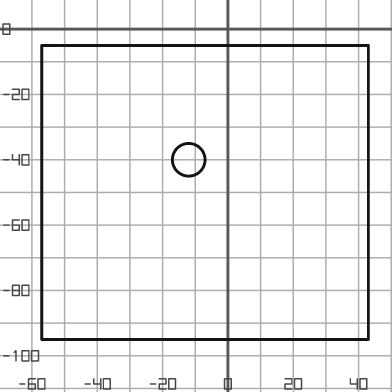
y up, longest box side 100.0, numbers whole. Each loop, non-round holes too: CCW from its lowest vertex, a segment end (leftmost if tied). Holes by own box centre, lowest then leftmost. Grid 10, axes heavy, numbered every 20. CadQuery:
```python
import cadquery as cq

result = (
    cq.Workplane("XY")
    .moveTo(-57.0, -95.0)
    .lineTo(43.0, -95.0)
    .lineTo(43.0, -5.0)
    .lineTo(-57.0, -5.0)
    .close()
    .moveTo(-12.0, -40.0)
    .circle(5.0)
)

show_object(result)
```